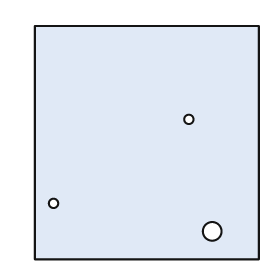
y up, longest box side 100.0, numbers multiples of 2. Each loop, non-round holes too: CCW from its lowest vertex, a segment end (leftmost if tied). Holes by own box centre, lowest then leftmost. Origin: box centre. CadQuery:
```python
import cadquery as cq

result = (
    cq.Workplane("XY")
    .moveTo(-48.0, -50.0)
    .lineTo(48.0, -50.0)
    .lineTo(48.0, 50.0)
    .lineTo(-48.0, 50.0)
    .close()
    .moveTo(28.0, -38.0)
    .circle(4.0)
    .moveTo(-40.0, -26.0)
    .circle(2.0)
    .moveTo(18.0, 10.0)
    .circle(2.0)
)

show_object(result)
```